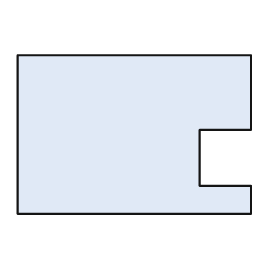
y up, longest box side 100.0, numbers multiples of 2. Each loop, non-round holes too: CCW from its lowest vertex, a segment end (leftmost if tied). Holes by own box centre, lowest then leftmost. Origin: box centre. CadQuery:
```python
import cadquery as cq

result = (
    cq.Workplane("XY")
    .moveTo(-50.0, -34.0)
    .lineTo(50.0, -34.0)
    .lineTo(50.0, -22.0)
    .lineTo(28.0, -22.0)
    .lineTo(28.0, 2.0)
    .lineTo(50.0, 2.0)
    .lineTo(50.0, 34.0)
    .lineTo(-50.0, 34.0)
    .close()
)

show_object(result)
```